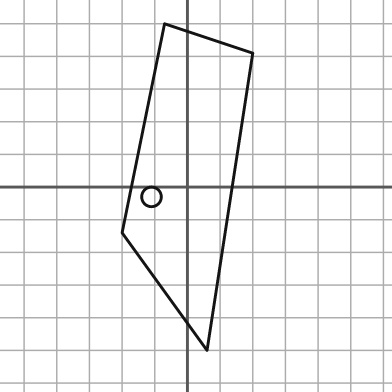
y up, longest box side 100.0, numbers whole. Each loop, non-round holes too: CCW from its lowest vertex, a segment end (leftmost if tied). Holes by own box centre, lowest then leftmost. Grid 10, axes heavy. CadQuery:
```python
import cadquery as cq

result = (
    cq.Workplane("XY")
    .moveTo(6.0, -50.0)
    .lineTo(20.0, 41.0)
    .lineTo(-7.0, 50.0)
    .lineTo(-20.0, -14.0)
    .close()
    .moveTo(-11.0, -3.0)
    .circle(3.0)
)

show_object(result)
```